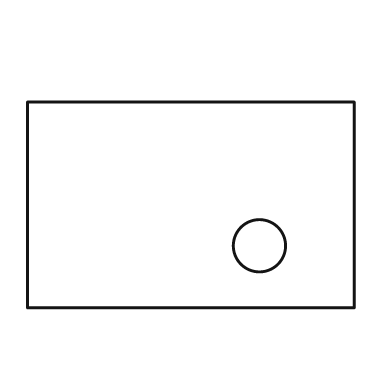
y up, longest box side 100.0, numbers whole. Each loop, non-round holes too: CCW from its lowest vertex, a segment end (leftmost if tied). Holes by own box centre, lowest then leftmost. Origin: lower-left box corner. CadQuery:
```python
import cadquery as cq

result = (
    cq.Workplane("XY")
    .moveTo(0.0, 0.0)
    .lineTo(100.0, 0.0)
    .lineTo(100.0, 63.0)
    .lineTo(0.0, 63.0)
    .close()
    .moveTo(71.0, 19.0)
    .circle(8.0)
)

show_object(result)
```